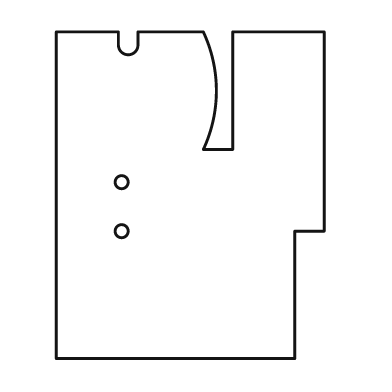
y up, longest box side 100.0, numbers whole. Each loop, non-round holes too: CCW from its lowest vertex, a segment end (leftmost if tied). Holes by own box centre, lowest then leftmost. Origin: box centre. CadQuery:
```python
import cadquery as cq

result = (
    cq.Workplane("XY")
    .moveTo(-41.0, -50.0)
    .lineTo(32.0, -50.0)
    .lineTo(32.0, -11.0)
    .lineTo(41.0, -11.0)
    .lineTo(41.0, 50.0)
    .lineTo(13.0, 50.0)
    .lineTo(13.0, 14.0)
    .lineTo(4.0, 14.0)
    .threePointArc((8.0, 32.0), (4.0, 50.0))
    .lineTo(-16.0, 50.0)
    .lineTo(-16.0, 46.0)
    .threePointArc((-19.0, 43.0), (-22.0, 46.0))
    .lineTo(-22.0, 50.0)
    .lineTo(-41.0, 50.0)
    .close()
    .moveTo(-21.0, -11.0)
    .circle(2.0)
    .moveTo(-21.0, 4.0)
    .circle(2.0)
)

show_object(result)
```